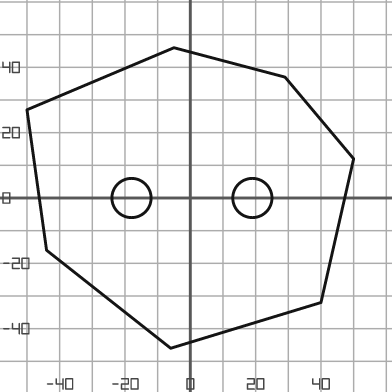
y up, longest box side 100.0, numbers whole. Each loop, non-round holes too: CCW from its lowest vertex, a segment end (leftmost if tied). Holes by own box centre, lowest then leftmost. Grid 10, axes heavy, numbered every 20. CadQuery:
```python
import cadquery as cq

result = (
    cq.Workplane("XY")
    .moveTo(-6.0, -46.0)
    .lineTo(40.0, -32.0)
    .lineTo(50.0, 12.0)
    .lineTo(29.0, 37.0)
    .lineTo(-5.0, 46.0)
    .lineTo(-50.0, 27.0)
    .lineTo(-44.0, -16.0)
    .close()
    .moveTo(-18.0, 0.0)
    .circle(6.0)
    .moveTo(19.0, 0.0)
    .circle(6.0)
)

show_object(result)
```